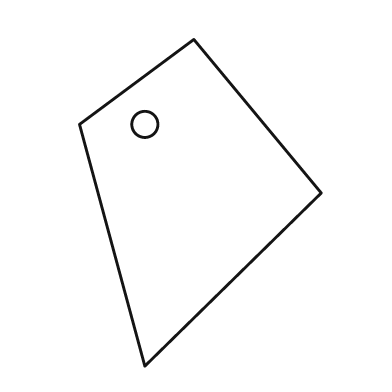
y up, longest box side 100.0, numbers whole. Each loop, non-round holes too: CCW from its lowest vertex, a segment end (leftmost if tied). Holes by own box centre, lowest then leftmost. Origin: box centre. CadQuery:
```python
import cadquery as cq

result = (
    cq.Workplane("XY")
    .moveTo(-17.0, -50.0)
    .lineTo(37.0, 3.0)
    .lineTo(-2.0, 50.0)
    .lineTo(-37.0, 24.0)
    .close()
    .moveTo(-17.0, 24.0)
    .circle(4.0)
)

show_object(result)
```